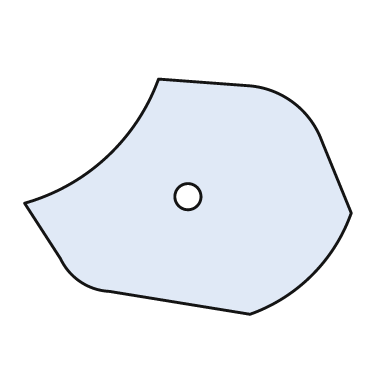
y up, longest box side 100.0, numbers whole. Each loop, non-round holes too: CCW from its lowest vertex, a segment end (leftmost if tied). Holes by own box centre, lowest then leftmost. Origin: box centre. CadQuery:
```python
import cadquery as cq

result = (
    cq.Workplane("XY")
    .moveTo(19.0, -36.0)
    .threePointArc((38.0, -24.0), (50.0, -5.0))
    .lineTo(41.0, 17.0)
    .threePointArc((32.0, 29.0), (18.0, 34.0))
    .lineTo(-9.0, 36.0)
    .threePointArc((-25.0, 12.0), (-50.0, -2.0))
    .lineTo(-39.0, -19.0)
    .threePointArc((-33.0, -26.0), (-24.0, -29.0))
    .close()
    .moveTo(0.0, 0.0)
    .circle(4.0)
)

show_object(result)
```